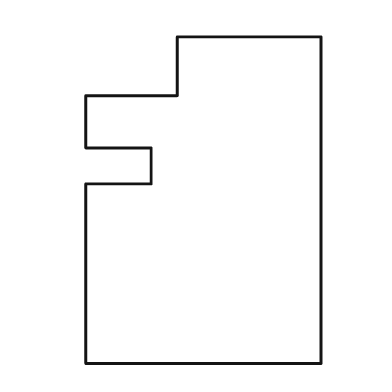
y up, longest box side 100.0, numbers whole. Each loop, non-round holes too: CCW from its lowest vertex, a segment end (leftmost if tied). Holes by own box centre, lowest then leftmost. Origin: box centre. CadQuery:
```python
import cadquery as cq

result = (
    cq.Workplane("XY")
    .moveTo(-36.0, -50.0)
    .lineTo(36.0, -50.0)
    .lineTo(36.0, 50.0)
    .lineTo(-8.0, 50.0)
    .lineTo(-8.0, 32.0)
    .lineTo(-36.0, 32.0)
    .lineTo(-36.0, 16.0)
    .lineTo(-16.0, 16.0)
    .lineTo(-16.0, 5.0)
    .lineTo(-36.0, 5.0)
    .close()
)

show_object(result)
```